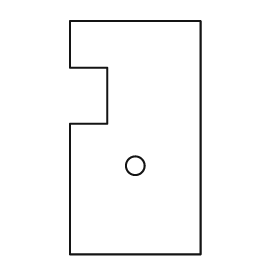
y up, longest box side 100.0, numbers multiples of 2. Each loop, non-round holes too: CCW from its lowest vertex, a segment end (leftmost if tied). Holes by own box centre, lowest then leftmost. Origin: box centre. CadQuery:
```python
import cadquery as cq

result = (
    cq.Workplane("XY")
    .moveTo(-28.0, -50.0)
    .lineTo(28.0, -50.0)
    .lineTo(28.0, 50.0)
    .lineTo(-28.0, 50.0)
    .lineTo(-28.0, 30.0)
    .lineTo(-12.0, 30.0)
    .lineTo(-12.0, 6.0)
    .lineTo(-28.0, 6.0)
    .close()
    .moveTo(0.0, -12.0)
    .circle(4.0)
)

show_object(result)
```